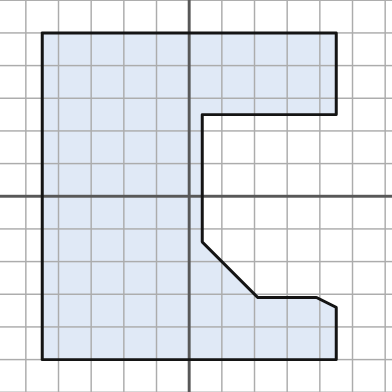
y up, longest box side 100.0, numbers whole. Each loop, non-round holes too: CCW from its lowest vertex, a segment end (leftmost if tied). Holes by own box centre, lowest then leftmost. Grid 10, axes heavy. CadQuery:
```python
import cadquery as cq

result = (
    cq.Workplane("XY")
    .moveTo(-45.0, -50.0)
    .lineTo(45.0, -50.0)
    .lineTo(45.0, -34.0)
    .lineTo(39.0, -31.0)
    .lineTo(21.0, -31.0)
    .lineTo(4.0, -14.0)
    .lineTo(4.0, 25.0)
    .lineTo(45.0, 25.0)
    .lineTo(45.0, 50.0)
    .lineTo(-45.0, 50.0)
    .close()
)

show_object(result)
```